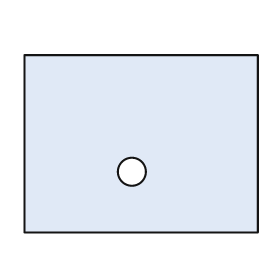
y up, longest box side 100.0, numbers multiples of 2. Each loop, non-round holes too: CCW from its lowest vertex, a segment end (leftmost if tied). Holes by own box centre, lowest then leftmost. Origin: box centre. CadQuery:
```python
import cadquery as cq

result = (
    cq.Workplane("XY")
    .moveTo(-50.0, -38.0)
    .lineTo(50.0, -38.0)
    .lineTo(50.0, 38.0)
    .lineTo(-50.0, 38.0)
    .close()
    .moveTo(-4.0, -12.0)
    .circle(6.0)
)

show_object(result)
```